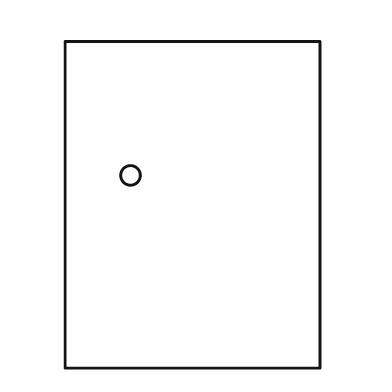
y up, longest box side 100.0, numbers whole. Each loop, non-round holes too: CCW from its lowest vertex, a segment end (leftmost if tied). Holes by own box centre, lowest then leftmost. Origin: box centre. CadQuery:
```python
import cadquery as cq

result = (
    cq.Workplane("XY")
    .moveTo(-39.0, -50.0)
    .lineTo(39.0, -50.0)
    .lineTo(39.0, 50.0)
    .lineTo(-39.0, 50.0)
    .close()
    .moveTo(-19.0, 9.0)
    .circle(3.0)
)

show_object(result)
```